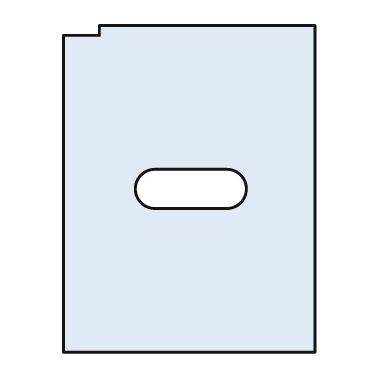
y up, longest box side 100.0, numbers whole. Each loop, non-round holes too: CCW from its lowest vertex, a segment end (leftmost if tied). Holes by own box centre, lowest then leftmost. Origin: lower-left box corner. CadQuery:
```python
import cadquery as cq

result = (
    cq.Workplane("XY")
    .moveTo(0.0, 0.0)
    .lineTo(77.0, 0.0)
    .lineTo(77.0, 100.0)
    .lineTo(11.0, 100.0)
    .lineTo(11.0, 97.0)
    .lineTo(0.0, 97.0)
    .close()
    .moveTo(28.0, 44.0)
    .lineTo(50.0, 44.0)
    .threePointArc((56.0, 50.0), (50.0, 56.0))
    .lineTo(28.0, 56.0)
    .threePointArc((22.0, 50.0), (28.0, 44.0))
    .close()
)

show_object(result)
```